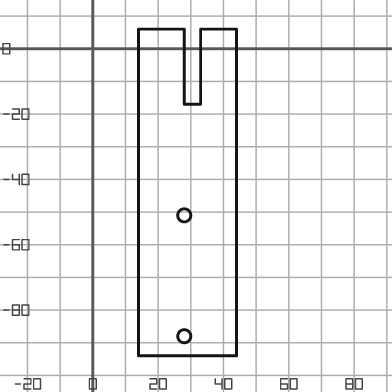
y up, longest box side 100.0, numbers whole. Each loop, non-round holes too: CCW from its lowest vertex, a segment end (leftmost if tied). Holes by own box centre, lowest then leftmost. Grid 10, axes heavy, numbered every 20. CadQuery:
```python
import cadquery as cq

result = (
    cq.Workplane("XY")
    .moveTo(14.0, -94.0)
    .lineTo(44.0, -94.0)
    .lineTo(44.0, 6.0)
    .lineTo(33.0, 6.0)
    .lineTo(33.0, -17.0)
    .lineTo(28.0, -17.0)
    .lineTo(28.0, 6.0)
    .lineTo(14.0, 6.0)
    .close()
    .moveTo(28.0, -88.0)
    .circle(2.0)
    .moveTo(28.0, -51.0)
    .circle(2.0)
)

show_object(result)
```